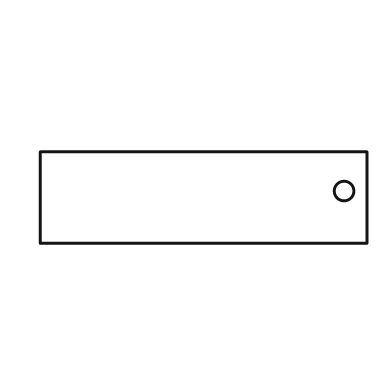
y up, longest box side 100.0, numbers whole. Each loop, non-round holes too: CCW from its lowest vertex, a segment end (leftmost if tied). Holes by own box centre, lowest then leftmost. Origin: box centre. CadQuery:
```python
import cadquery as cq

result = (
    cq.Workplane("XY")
    .moveTo(-50.0, -14.0)
    .lineTo(50.0, -14.0)
    .lineTo(50.0, 14.0)
    .lineTo(-50.0, 14.0)
    .close()
    .moveTo(43.0, 2.0)
    .circle(3.0)
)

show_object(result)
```